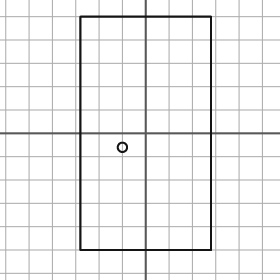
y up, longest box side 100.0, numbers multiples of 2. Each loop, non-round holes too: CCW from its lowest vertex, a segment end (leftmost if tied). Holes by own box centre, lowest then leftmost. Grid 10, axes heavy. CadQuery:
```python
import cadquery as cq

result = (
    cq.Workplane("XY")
    .moveTo(-28.0, -50.0)
    .lineTo(28.0, -50.0)
    .lineTo(28.0, 50.0)
    .lineTo(-28.0, 50.0)
    .close()
    .moveTo(-10.0, -6.0)
    .circle(2.0)
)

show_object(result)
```